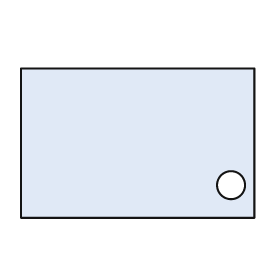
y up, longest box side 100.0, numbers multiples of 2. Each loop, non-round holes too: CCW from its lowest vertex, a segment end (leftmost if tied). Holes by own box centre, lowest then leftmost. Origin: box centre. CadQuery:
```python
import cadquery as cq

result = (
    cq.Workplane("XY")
    .moveTo(-50.0, -32.0)
    .lineTo(50.0, -32.0)
    .lineTo(50.0, 32.0)
    .lineTo(-50.0, 32.0)
    .close()
    .moveTo(40.0, -18.0)
    .circle(6.0)
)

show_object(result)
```